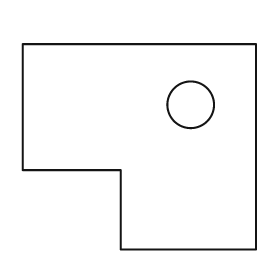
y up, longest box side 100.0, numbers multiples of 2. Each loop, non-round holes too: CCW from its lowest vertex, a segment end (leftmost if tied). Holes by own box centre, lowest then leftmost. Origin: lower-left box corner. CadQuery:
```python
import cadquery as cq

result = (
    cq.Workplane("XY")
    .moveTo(42.0, 0.0)
    .lineTo(100.0, 0.0)
    .lineTo(100.0, 88.0)
    .lineTo(0.0, 88.0)
    .lineTo(0.0, 34.0)
    .lineTo(42.0, 34.0)
    .close()
    .moveTo(72.0, 62.0)
    .circle(10.0)
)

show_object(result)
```